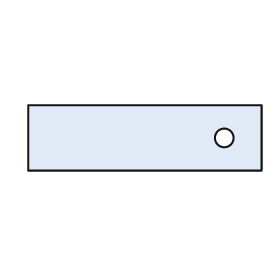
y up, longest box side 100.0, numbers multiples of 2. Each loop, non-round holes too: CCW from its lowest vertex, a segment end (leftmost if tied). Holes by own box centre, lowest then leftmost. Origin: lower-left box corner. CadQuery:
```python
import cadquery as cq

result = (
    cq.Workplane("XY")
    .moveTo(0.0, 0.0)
    .lineTo(100.0, 0.0)
    .lineTo(100.0, 28.0)
    .lineTo(0.0, 28.0)
    .close()
    .moveTo(84.0, 14.0)
    .circle(4.0)
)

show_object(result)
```